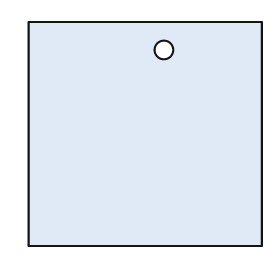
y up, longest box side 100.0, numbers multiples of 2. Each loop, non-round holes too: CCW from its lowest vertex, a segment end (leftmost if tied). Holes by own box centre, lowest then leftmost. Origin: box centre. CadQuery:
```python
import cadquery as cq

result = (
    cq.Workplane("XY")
    .moveTo(-50.0, -48.0)
    .lineTo(50.0, -48.0)
    .lineTo(50.0, 48.0)
    .lineTo(-50.0, 48.0)
    .close()
    .moveTo(8.0, 36.0)
    .circle(4.0)
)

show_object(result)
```